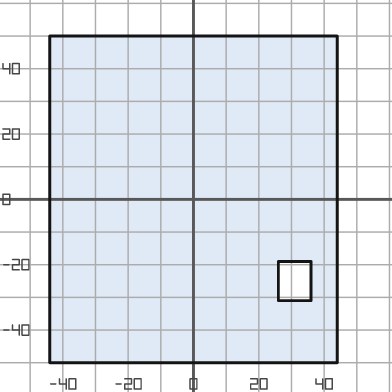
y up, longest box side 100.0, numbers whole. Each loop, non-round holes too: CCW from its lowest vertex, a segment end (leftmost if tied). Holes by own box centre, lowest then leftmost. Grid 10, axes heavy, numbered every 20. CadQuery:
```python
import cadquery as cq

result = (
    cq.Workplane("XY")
    .moveTo(-44.0, -50.0)
    .lineTo(44.0, -50.0)
    .lineTo(44.0, 50.0)
    .lineTo(-44.0, 50.0)
    .close()
    .moveTo(26.0, -31.0)
    .lineTo(36.0, -31.0)
    .lineTo(36.0, -19.0)
    .lineTo(26.0, -19.0)
    .close()
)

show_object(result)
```